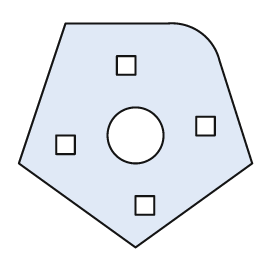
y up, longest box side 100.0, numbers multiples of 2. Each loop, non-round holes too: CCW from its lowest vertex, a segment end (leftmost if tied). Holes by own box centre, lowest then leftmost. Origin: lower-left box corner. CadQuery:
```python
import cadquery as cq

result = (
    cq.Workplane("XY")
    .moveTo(50.0, 0.0)
    .lineTo(100.0, 36.0)
    .lineTo(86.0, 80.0)
    .threePointArc((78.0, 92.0), (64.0, 96.0))
    .lineTo(20.0, 96.0)
    .lineTo(0.0, 36.0)
    .close()
    .moveTo(50.0, 14.0)
    .lineTo(58.0, 14.0)
    .lineTo(58.0, 22.0)
    .lineTo(50.0, 22.0)
    .close()
    .moveTo(16.0, 40.0)
    .lineTo(24.0, 40.0)
    .lineTo(24.0, 48.0)
    .lineTo(16.0, 48.0)
    .close()
    .moveTo(50.0, 48.0)
    .circle(12.0)
    .moveTo(76.0, 48.0)
    .lineTo(84.0, 48.0)
    .lineTo(84.0, 56.0)
    .lineTo(76.0, 56.0)
    .close()
    .moveTo(42.0, 74.0)
    .lineTo(50.0, 74.0)
    .lineTo(50.0, 82.0)
    .lineTo(42.0, 82.0)
    .close()
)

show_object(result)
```